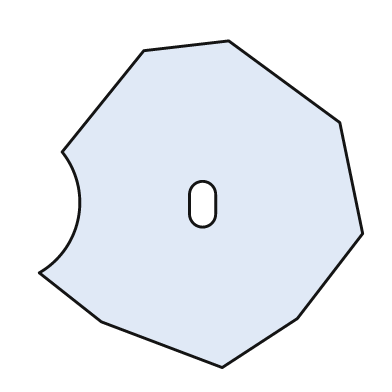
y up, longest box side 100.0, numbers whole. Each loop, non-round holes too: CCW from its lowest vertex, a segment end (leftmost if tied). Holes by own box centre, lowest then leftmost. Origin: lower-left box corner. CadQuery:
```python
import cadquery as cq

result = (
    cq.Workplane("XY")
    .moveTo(56.0, 0.0)
    .lineTo(79.0, 15.0)
    .lineTo(99.0, 41.0)
    .lineTo(92.0, 75.0)
    .lineTo(58.0, 100.0)
    .lineTo(32.0, 97.0)
    .lineTo(7.0, 66.0)
    .threePointArc((12.0, 46.0), (0.0, 29.0))
    .lineTo(19.0, 14.0)
    .close()
    .moveTo(46.0, 47.0)
    .threePointArc((50.0, 43.0), (54.0, 47.0))
    .lineTo(54.0, 53.0)
    .threePointArc((50.0, 57.0), (46.0, 53.0))
    .close()
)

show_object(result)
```